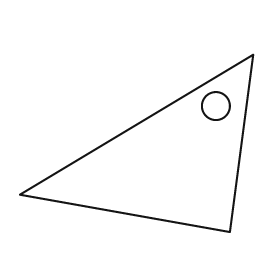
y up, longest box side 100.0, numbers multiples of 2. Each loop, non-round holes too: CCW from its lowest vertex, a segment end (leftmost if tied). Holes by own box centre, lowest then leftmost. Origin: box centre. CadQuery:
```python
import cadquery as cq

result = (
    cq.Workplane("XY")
    .moveTo(40.0, -38.0)
    .lineTo(50.0, 38.0)
    .lineTo(-50.0, -22.0)
    .close()
    .moveTo(34.0, 16.0)
    .circle(6.0)
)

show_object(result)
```